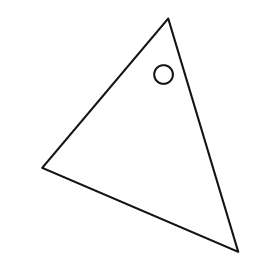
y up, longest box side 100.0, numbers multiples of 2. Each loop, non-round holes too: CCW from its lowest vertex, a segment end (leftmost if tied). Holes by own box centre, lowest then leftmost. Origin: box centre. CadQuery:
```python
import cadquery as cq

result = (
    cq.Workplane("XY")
    .moveTo(42.0, -50.0)
    .lineTo(12.0, 50.0)
    .lineTo(-42.0, -14.0)
    .close()
    .moveTo(10.0, 26.0)
    .circle(4.0)
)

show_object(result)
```